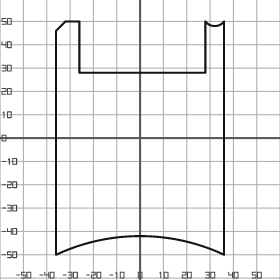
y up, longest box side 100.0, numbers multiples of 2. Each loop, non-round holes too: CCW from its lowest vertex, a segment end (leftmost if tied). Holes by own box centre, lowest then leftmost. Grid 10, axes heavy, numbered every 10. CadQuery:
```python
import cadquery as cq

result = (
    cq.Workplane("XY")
    .moveTo(-36.0, -50.0)
    .threePointArc((0.0, -42.0), (36.0, -50.0))
    .lineTo(36.0, 50.0)
    .threePointArc((32.0, 48.0), (28.0, 50.0))
    .lineTo(28.0, 28.0)
    .lineTo(-26.0, 28.0)
    .lineTo(-26.0, 50.0)
    .lineTo(-32.0, 50.0)
    .lineTo(-36.0, 46.0)
    .close()
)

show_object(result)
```